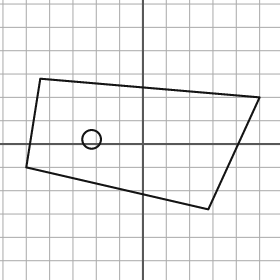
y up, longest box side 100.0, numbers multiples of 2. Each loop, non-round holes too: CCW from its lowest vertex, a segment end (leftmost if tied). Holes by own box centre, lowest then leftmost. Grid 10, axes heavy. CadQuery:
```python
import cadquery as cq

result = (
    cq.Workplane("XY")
    .moveTo(28.0, -28.0)
    .lineTo(50.0, 20.0)
    .lineTo(-44.0, 28.0)
    .lineTo(-50.0, -10.0)
    .close()
    .moveTo(-22.0, 2.0)
    .circle(4.0)
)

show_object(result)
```